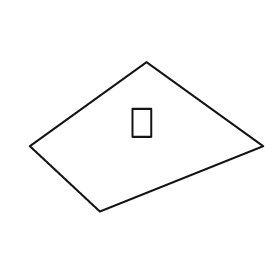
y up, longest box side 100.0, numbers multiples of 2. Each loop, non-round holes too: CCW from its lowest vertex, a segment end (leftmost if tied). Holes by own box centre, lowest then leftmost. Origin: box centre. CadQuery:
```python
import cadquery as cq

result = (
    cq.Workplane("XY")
    .moveTo(-20.0, -32.0)
    .lineTo(50.0, -4.0)
    .lineTo(0.0, 32.0)
    .lineTo(-50.0, -4.0)
    .close()
    .moveTo(-6.0, 0.0)
    .lineTo(2.0, 0.0)
    .lineTo(2.0, 12.0)
    .lineTo(-6.0, 12.0)
    .close()
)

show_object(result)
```